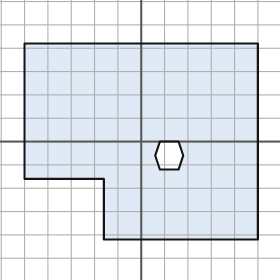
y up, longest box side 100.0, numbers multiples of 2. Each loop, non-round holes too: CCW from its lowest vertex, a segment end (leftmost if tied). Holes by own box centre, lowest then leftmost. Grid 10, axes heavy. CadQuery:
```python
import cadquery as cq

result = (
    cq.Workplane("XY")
    .moveTo(-16.0, -42.0)
    .lineTo(50.0, -42.0)
    .lineTo(50.0, 42.0)
    .lineTo(-50.0, 42.0)
    .lineTo(-50.0, -16.0)
    .lineTo(-16.0, -16.0)
    .close()
    .moveTo(8.0, -12.0)
    .lineTo(16.0, -12.0)
    .lineTo(18.0, -6.0)
    .lineTo(16.0, 0.0)
    .lineTo(8.0, 0.0)
    .lineTo(6.0, -6.0)
    .close()
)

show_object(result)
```